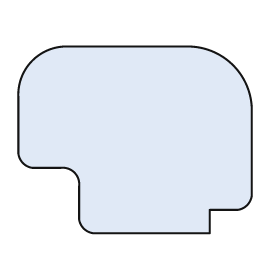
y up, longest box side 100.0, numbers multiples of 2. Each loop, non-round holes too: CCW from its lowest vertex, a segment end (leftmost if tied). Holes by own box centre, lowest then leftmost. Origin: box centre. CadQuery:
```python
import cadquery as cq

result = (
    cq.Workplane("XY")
    .moveTo(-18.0, -40.0)
    .lineTo(32.0, -40.0)
    .lineTo(32.0, -30.0)
    .lineTo(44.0, -30.0)
    .threePointArc((48.0, -28.0), (50.0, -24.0))
    .lineTo(50.0, 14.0)
    .threePointArc((42.0, 32.0), (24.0, 40.0))
    .lineTo(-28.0, 40.0)
    .threePointArc((-44.0, 34.0), (-50.0, 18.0))
    .lineTo(-50.0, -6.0)
    .threePointArc((-48.0, -10.0), (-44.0, -12.0))
    .lineTo(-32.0, -12.0)
    .threePointArc((-26.0, -14.0), (-24.0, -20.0))
    .lineTo(-24.0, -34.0)
    .threePointArc((-22.0, -38.0), (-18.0, -40.0))
    .close()
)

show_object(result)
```